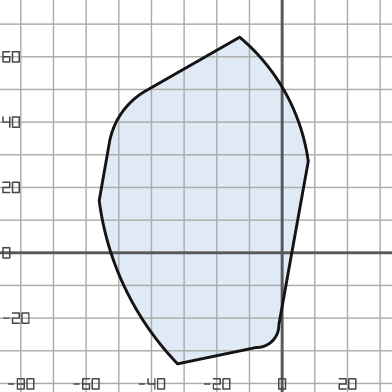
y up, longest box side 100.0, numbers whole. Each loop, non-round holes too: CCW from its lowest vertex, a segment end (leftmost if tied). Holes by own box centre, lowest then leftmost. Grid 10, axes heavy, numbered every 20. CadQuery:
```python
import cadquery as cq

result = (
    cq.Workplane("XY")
    .moveTo(-32.0, -34.0)
    .lineTo(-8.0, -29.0)
    .threePointArc((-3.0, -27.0), (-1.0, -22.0))
    .lineTo(8.0, 28.0)
    .threePointArc((1.0, 49.0), (-13.0, 66.0))
    .lineTo(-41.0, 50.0)
    .threePointArc((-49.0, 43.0), (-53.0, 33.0))
    .lineTo(-56.0, 16.0)
    .threePointArc((-48.0, -11.0), (-32.0, -34.0))
    .close()
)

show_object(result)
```